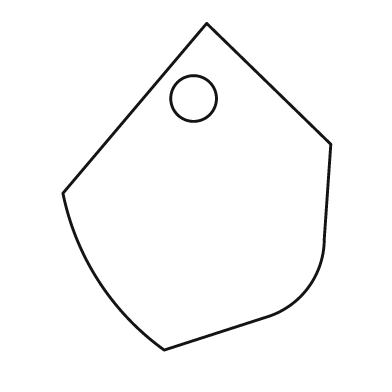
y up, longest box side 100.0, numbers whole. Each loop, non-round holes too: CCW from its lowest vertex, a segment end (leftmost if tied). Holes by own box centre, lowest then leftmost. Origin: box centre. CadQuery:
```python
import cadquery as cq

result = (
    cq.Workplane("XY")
    .moveTo(-10.0, -50.0)
    .lineTo(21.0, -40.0)
    .threePointArc((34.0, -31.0), (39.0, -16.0))
    .lineTo(41.0, 13.0)
    .lineTo(3.0, 50.0)
    .lineTo(-41.0, -2.0)
    .threePointArc((-30.0, -29.0), (-10.0, -50.0))
    .close()
    .moveTo(-1.0, 27.0)
    .circle(7.0)
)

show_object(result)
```